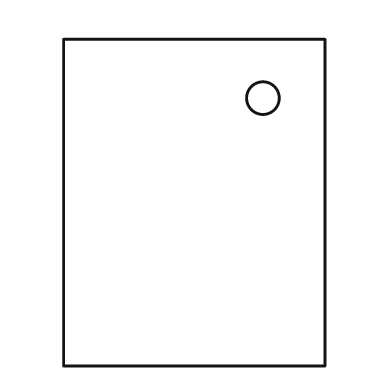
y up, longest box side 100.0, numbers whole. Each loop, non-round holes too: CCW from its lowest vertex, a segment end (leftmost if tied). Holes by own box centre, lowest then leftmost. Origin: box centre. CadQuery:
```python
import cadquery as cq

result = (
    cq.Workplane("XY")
    .moveTo(-40.0, -50.0)
    .lineTo(40.0, -50.0)
    .lineTo(40.0, 50.0)
    .lineTo(-40.0, 50.0)
    .close()
    .moveTo(21.0, 32.0)
    .circle(5.0)
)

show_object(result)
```